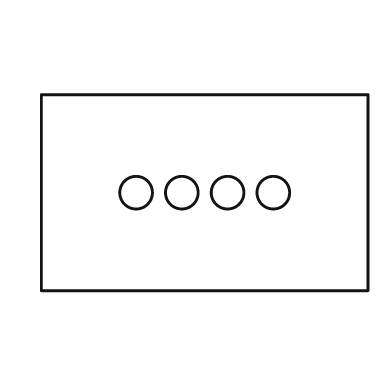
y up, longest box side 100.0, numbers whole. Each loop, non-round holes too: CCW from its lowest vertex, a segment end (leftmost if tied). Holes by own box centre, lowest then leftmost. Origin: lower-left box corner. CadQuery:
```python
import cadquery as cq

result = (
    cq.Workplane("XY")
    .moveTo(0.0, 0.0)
    .lineTo(100.0, 0.0)
    .lineTo(100.0, 60.0)
    .lineTo(0.0, 60.0)
    .close()
    .moveTo(29.0, 30.0)
    .circle(5.0)
    .moveTo(43.0, 30.0)
    .circle(5.0)
    .moveTo(57.0, 30.0)
    .circle(5.0)
    .moveTo(71.0, 30.0)
    .circle(5.0)
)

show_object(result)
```